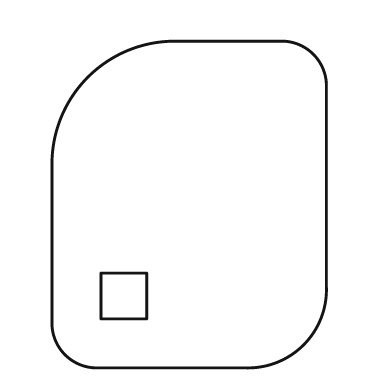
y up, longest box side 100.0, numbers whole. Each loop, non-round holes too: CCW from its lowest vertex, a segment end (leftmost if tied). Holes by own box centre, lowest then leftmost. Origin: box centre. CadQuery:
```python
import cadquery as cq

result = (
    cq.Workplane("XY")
    .moveTo(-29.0, -50.0)
    .lineTo(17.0, -50.0)
    .threePointArc((35.0, -43.0), (42.0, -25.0))
    .lineTo(42.0, 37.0)
    .threePointArc((38.0, 46.0), (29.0, 50.0))
    .lineTo(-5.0, 50.0)
    .threePointArc((-31.0, 39.0), (-42.0, 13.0))
    .lineTo(-42.0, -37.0)
    .threePointArc((-38.0, -46.0), (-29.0, -50.0))
    .close()
    .moveTo(-27.0, -35.0)
    .lineTo(-13.0, -35.0)
    .lineTo(-13.0, -21.0)
    .lineTo(-27.0, -21.0)
    .close()
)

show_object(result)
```